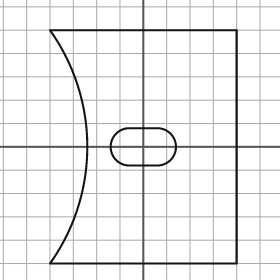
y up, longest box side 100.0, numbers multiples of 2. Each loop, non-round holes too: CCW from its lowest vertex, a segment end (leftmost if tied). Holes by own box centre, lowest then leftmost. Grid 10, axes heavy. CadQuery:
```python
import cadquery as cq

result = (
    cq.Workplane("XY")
    .moveTo(-40.0, -50.0)
    .lineTo(40.0, -50.0)
    .lineTo(40.0, 50.0)
    .lineTo(-40.0, 50.0)
    .threePointArc((-24.0, 0.0), (-40.0, -50.0))
    .close()
    .moveTo(-6.0, -8.0)
    .lineTo(6.0, -8.0)
    .threePointArc((14.0, 0.0), (6.0, 8.0))
    .lineTo(-6.0, 8.0)
    .threePointArc((-14.0, 0.0), (-6.0, -8.0))
    .close()
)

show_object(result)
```